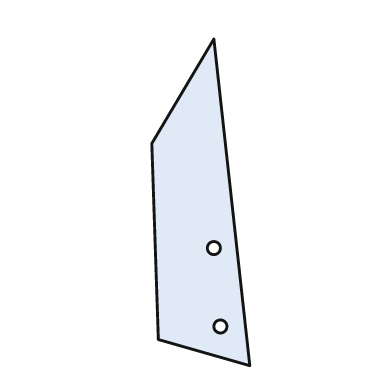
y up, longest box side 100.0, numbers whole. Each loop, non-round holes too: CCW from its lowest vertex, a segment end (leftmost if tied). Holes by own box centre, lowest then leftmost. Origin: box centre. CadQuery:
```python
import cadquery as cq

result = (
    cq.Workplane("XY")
    .moveTo(15.0, -50.0)
    .lineTo(4.0, 50.0)
    .lineTo(-15.0, 18.0)
    .lineTo(-13.0, -42.0)
    .close()
    .moveTo(6.0, -38.0)
    .circle(2.0)
    .moveTo(4.0, -14.0)
    .circle(2.0)
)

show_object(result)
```